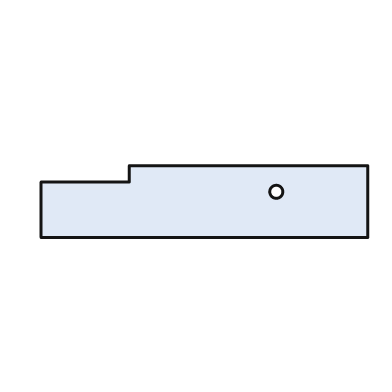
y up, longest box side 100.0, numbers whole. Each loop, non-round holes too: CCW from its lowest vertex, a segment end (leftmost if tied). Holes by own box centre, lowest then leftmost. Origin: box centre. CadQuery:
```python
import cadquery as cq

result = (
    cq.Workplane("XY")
    .moveTo(-50.0, -11.0)
    .lineTo(50.0, -11.0)
    .lineTo(50.0, 11.0)
    .lineTo(-23.0, 11.0)
    .lineTo(-23.0, 6.0)
    .lineTo(-50.0, 6.0)
    .close()
    .moveTo(22.0, 3.0)
    .circle(2.0)
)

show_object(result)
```